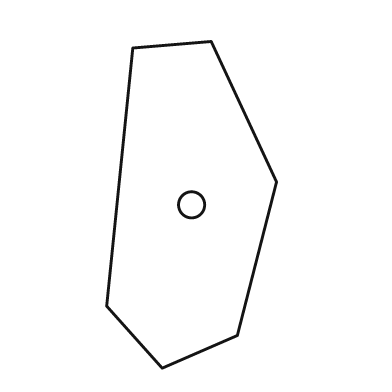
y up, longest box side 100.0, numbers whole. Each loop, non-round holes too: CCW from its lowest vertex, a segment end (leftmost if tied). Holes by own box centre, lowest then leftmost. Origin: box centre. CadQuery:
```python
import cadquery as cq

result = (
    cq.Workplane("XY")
    .moveTo(-9.0, -50.0)
    .lineTo(14.0, -40.0)
    .lineTo(26.0, 7.0)
    .lineTo(6.0, 50.0)
    .lineTo(-18.0, 48.0)
    .lineTo(-26.0, -31.0)
    .close()
    .moveTo(0.0, 0.0)
    .circle(4.0)
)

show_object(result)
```